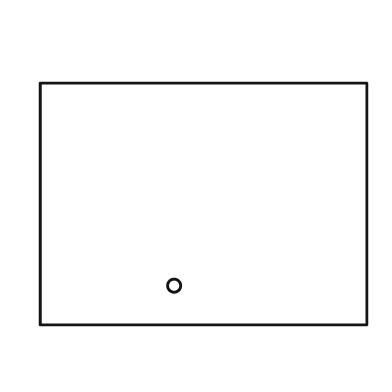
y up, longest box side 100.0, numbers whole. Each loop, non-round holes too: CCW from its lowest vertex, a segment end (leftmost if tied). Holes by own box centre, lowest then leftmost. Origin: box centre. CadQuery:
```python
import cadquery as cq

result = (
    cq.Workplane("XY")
    .moveTo(-50.0, -37.0)
    .lineTo(50.0, -37.0)
    .lineTo(50.0, 37.0)
    .lineTo(-50.0, 37.0)
    .close()
    .moveTo(-9.0, -25.0)
    .circle(2.0)
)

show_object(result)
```